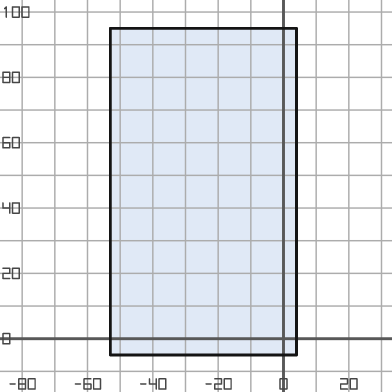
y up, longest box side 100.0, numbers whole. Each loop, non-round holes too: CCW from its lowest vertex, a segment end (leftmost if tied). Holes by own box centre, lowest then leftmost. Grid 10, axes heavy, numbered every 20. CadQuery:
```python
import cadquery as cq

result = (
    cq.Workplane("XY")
    .moveTo(-53.0, -5.0)
    .lineTo(4.0, -5.0)
    .lineTo(4.0, 95.0)
    .lineTo(-53.0, 95.0)
    .close()
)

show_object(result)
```